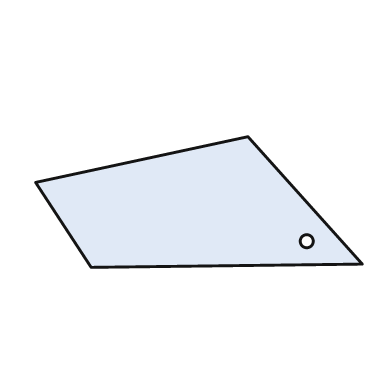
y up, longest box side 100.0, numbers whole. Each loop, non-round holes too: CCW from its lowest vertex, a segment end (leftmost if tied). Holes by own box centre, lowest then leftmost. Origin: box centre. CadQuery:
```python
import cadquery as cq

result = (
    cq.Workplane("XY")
    .moveTo(-33.0, -20.0)
    .lineTo(50.0, -19.0)
    .lineTo(15.0, 20.0)
    .lineTo(-50.0, 6.0)
    .close()
    .moveTo(33.0, -12.0)
    .circle(2.0)
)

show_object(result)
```